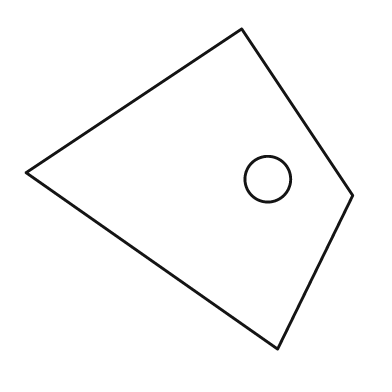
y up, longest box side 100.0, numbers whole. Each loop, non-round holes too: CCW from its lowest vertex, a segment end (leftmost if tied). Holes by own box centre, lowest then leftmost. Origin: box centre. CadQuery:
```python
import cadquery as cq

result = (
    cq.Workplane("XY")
    .moveTo(27.0, -49.0)
    .lineTo(50.0, -2.0)
    .lineTo(16.0, 49.0)
    .lineTo(-50.0, 5.0)
    .close()
    .moveTo(24.0, 3.0)
    .circle(7.0)
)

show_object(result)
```